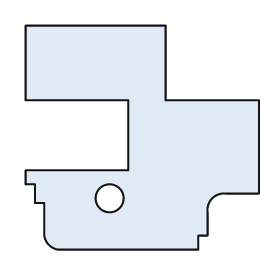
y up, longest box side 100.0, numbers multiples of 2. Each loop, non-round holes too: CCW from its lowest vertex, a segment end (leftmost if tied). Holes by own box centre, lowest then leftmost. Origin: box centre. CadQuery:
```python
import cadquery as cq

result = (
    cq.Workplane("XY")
    .moveTo(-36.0, -48.0)
    .lineTo(24.0, -48.0)
    .lineTo(24.0, -42.0)
    .lineTo(28.0, -42.0)
    .lineTo(28.0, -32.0)
    .threePointArc((30.0, -26.0), (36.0, -24.0))
    .lineTo(50.0, -24.0)
    .lineTo(50.0, 16.0)
    .lineTo(10.0, 16.0)
    .lineTo(10.0, 48.0)
    .lineTo(-50.0, 48.0)
    .lineTo(-50.0, 16.0)
    .lineTo(-6.0, 16.0)
    .lineTo(-6.0, -14.0)
    .lineTo(-50.0, -14.0)
    .lineTo(-50.0, -20.0)
    .lineTo(-46.0, -20.0)
    .lineTo(-46.0, -28.0)
    .lineTo(-42.0, -28.0)
    .lineTo(-42.0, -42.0)
    .threePointArc((-40.0, -46.0), (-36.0, -48.0))
    .close()
    .moveTo(-14.0, -26.0)
    .circle(6.0)
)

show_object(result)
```